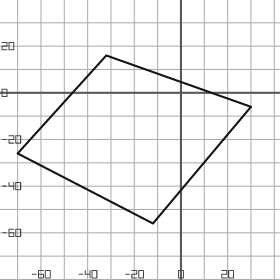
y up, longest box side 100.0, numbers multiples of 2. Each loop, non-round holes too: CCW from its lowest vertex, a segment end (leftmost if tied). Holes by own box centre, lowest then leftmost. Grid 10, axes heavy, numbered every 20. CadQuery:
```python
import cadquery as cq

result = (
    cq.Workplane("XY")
    .moveTo(-12.0, -56.0)
    .lineTo(30.0, -6.0)
    .lineTo(-32.0, 16.0)
    .lineTo(-70.0, -26.0)
    .close()
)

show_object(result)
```